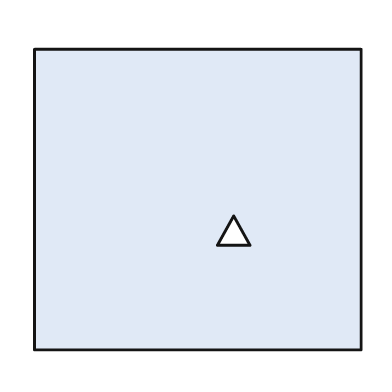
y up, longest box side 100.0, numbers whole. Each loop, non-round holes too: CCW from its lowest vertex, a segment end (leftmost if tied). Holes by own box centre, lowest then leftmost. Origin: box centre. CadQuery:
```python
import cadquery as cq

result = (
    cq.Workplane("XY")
    .moveTo(-50.0, -46.0)
    .lineTo(50.0, -46.0)
    .lineTo(50.0, 46.0)
    .lineTo(-50.0, 46.0)
    .close()
    .moveTo(6.0, -14.0)
    .lineTo(16.0, -14.0)
    .lineTo(11.0, -5.0)
    .close()
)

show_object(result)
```